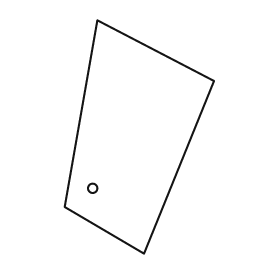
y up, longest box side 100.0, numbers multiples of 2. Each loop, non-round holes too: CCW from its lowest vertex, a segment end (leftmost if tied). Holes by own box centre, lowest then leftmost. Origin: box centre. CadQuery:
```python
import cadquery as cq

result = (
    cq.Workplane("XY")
    .moveTo(2.0, -50.0)
    .lineTo(32.0, 24.0)
    .lineTo(-18.0, 50.0)
    .lineTo(-32.0, -30.0)
    .close()
    .moveTo(-20.0, -22.0)
    .circle(2.0)
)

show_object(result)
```